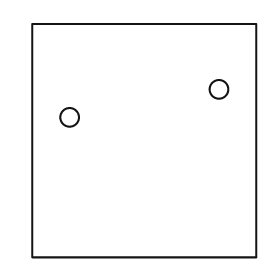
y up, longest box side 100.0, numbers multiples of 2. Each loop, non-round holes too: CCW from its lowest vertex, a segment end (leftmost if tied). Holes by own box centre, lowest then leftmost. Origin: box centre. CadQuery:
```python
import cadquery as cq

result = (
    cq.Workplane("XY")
    .moveTo(-48.0, -50.0)
    .lineTo(48.0, -50.0)
    .lineTo(48.0, 50.0)
    .lineTo(-48.0, 50.0)
    .close()
    .moveTo(-32.0, 10.0)
    .circle(4.0)
    .moveTo(32.0, 22.0)
    .circle(4.0)
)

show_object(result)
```